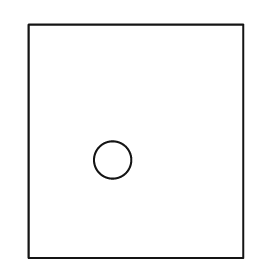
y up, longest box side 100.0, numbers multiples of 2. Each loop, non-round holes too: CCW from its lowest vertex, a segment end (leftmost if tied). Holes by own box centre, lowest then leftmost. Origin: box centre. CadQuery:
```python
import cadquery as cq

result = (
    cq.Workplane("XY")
    .moveTo(-46.0, -50.0)
    .lineTo(46.0, -50.0)
    .lineTo(46.0, 50.0)
    .lineTo(-46.0, 50.0)
    .close()
    .moveTo(-10.0, -8.0)
    .circle(8.0)
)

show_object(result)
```